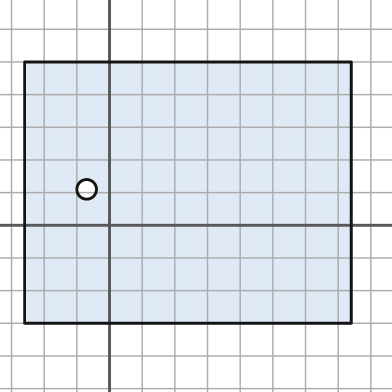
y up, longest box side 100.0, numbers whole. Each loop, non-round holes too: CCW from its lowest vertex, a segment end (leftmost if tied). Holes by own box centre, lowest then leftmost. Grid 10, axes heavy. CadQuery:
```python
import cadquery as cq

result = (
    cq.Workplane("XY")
    .moveTo(-26.0, -30.0)
    .lineTo(74.0, -30.0)
    .lineTo(74.0, 50.0)
    .lineTo(-26.0, 50.0)
    .close()
    .moveTo(-7.0, 11.0)
    .circle(3.0)
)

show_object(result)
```